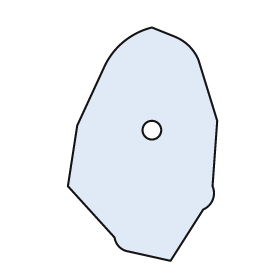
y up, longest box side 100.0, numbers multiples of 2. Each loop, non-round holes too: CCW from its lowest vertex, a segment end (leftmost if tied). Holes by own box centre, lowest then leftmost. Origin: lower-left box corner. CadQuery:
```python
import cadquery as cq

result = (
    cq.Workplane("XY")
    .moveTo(44.0, 0.0)
    .lineTo(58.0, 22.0)
    .threePointArc((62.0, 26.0), (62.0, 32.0))
    .lineTo(64.0, 60.0)
    .lineTo(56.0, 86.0)
    .threePointArc((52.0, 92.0), (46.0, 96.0))
    .lineTo(36.0, 100.0)
    .threePointArc((24.0, 94.0), (16.0, 84.0))
    .lineTo(4.0, 58.0)
    .lineTo(0.0, 32.0)
    .lineTo(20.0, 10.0)
    .threePointArc((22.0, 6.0), (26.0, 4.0))
    .close()
    .moveTo(36.0, 56.0)
    .circle(4.0)
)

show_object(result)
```